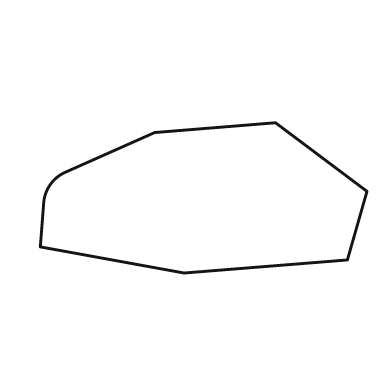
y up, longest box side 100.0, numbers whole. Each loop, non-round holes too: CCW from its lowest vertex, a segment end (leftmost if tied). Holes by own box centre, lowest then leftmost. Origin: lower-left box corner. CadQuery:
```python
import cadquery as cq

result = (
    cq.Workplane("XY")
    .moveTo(44.0, 0.0)
    .lineTo(94.0, 4.0)
    .lineTo(100.0, 25.0)
    .lineTo(72.0, 46.0)
    .lineTo(35.0, 43.0)
    .lineTo(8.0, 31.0)
    .threePointArc((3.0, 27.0), (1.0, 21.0))
    .lineTo(0.0, 8.0)
    .close()
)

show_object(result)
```